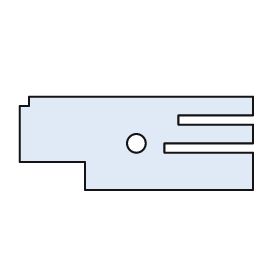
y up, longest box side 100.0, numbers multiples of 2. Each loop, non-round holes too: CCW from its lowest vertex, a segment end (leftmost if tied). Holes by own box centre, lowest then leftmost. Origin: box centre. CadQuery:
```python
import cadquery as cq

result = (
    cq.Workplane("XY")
    .moveTo(-22.0, -20.0)
    .lineTo(50.0, -20.0)
    .lineTo(50.0, -4.0)
    .lineTo(12.0, -4.0)
    .lineTo(12.0, 0.0)
    .lineTo(50.0, 0.0)
    .lineTo(50.0, 8.0)
    .lineTo(18.0, 8.0)
    .lineTo(18.0, 12.0)
    .lineTo(50.0, 12.0)
    .lineTo(50.0, 20.0)
    .lineTo(-46.0, 20.0)
    .lineTo(-46.0, 16.0)
    .lineTo(-50.0, 16.0)
    .lineTo(-50.0, -8.0)
    .lineTo(-22.0, -8.0)
    .close()
    .moveTo(0.0, 0.0)
    .circle(4.0)
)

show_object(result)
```